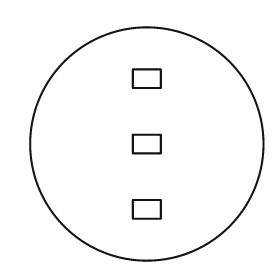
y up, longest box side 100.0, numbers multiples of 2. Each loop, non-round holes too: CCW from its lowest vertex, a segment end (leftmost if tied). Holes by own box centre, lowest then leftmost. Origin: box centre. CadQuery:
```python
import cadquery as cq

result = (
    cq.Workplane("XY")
    .moveTo(0.0, 0.0)
    .circle(50.0)
    .moveTo(-6.0, -32.0)
    .lineTo(6.0, -32.0)
    .lineTo(6.0, -24.0)
    .lineTo(-6.0, -24.0)
    .close()
    .moveTo(-6.0, -4.0)
    .lineTo(6.0, -4.0)
    .lineTo(6.0, 4.0)
    .lineTo(-6.0, 4.0)
    .close()
    .moveTo(-6.0, 24.0)
    .lineTo(6.0, 24.0)
    .lineTo(6.0, 32.0)
    .lineTo(-6.0, 32.0)
    .close()
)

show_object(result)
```